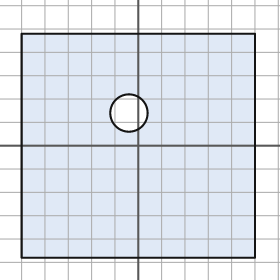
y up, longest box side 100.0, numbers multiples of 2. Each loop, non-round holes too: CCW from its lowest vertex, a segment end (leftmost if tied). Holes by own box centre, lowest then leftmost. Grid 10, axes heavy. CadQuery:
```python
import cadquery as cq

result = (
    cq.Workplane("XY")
    .moveTo(-50.0, -48.0)
    .lineTo(50.0, -48.0)
    .lineTo(50.0, 48.0)
    .lineTo(-50.0, 48.0)
    .close()
    .moveTo(-4.0, 14.0)
    .circle(8.0)
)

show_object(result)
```